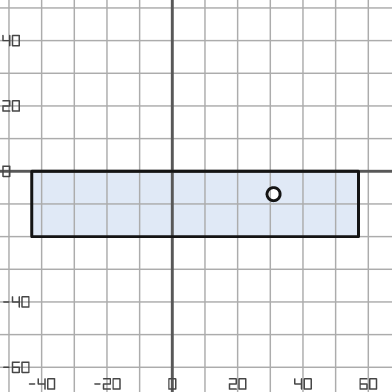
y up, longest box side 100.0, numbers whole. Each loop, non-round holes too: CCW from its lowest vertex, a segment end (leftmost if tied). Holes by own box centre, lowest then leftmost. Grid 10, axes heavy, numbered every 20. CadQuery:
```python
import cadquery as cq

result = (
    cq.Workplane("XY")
    .moveTo(-43.0, -20.0)
    .lineTo(57.0, -20.0)
    .lineTo(57.0, 0.0)
    .lineTo(-43.0, 0.0)
    .close()
    .moveTo(31.0, -7.0)
    .circle(2.0)
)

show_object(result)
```